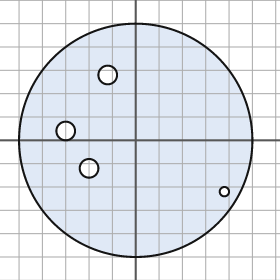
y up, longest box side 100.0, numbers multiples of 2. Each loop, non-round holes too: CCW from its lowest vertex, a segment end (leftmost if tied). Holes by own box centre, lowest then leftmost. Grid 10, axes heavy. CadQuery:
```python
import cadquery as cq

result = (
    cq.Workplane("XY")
    .moveTo(0.0, 0.0)
    .circle(50.0)
    .moveTo(38.0, -22.0)
    .circle(2.0)
    .moveTo(-20.0, -12.0)
    .circle(4.0)
    .moveTo(-30.0, 4.0)
    .circle(4.0)
    .moveTo(-12.0, 28.0)
    .circle(4.0)
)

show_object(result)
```